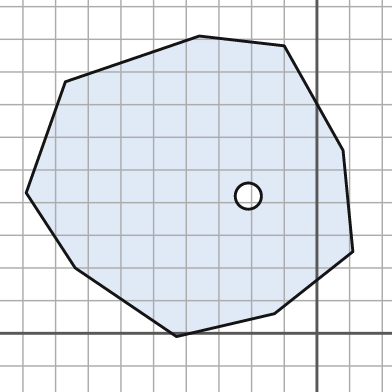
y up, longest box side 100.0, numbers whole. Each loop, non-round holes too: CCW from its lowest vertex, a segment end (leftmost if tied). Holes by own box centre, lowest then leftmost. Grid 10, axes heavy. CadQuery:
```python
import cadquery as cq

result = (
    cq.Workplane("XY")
    .moveTo(-43.0, -1.0)
    .lineTo(-13.0, 6.0)
    .lineTo(11.0, 25.0)
    .lineTo(8.0, 56.0)
    .lineTo(-10.0, 88.0)
    .lineTo(-36.0, 91.0)
    .lineTo(-77.0, 77.0)
    .lineTo(-89.0, 43.0)
    .lineTo(-74.0, 20.0)
    .close()
    .moveTo(-21.0, 42.0)
    .circle(4.0)
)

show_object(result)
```